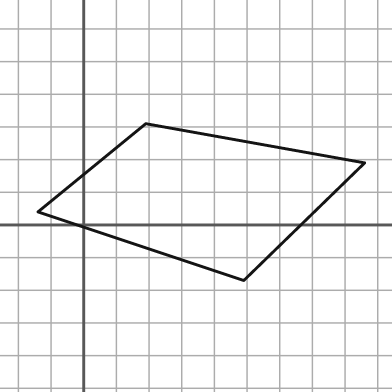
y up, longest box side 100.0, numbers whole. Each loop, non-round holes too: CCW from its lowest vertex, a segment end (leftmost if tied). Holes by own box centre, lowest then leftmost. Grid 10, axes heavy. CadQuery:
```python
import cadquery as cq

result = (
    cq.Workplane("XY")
    .moveTo(49.0, -17.0)
    .lineTo(86.0, 19.0)
    .lineTo(19.0, 31.0)
    .lineTo(-14.0, 4.0)
    .close()
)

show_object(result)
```